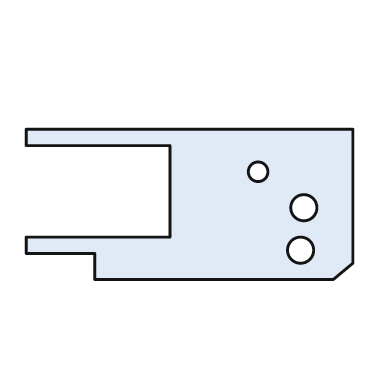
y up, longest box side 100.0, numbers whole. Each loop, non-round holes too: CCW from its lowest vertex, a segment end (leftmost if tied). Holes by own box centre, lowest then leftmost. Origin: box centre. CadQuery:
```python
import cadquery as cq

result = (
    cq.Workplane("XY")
    .moveTo(-29.0, -23.0)
    .lineTo(44.0, -23.0)
    .lineTo(50.0, -18.0)
    .lineTo(50.0, 23.0)
    .lineTo(-50.0, 23.0)
    .lineTo(-50.0, 18.0)
    .lineTo(-6.0, 18.0)
    .lineTo(-6.0, -10.0)
    .lineTo(-50.0, -10.0)
    .lineTo(-50.0, -15.0)
    .lineTo(-29.0, -15.0)
    .close()
    .moveTo(34.0, -14.0)
    .circle(4.0)
    .moveTo(35.0, -1.0)
    .circle(4.0)
    .moveTo(21.0, 10.0)
    .circle(3.0)
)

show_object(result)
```